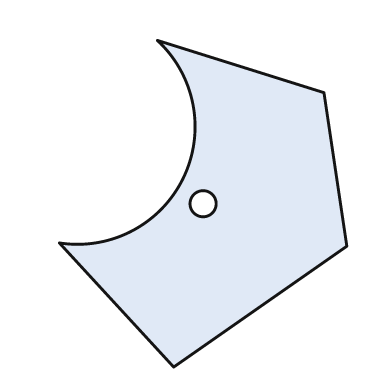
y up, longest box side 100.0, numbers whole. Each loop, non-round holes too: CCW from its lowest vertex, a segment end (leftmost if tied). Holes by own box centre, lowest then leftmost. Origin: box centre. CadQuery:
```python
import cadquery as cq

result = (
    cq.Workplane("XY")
    .moveTo(-9.0, -50.0)
    .lineTo(44.0, -13.0)
    .lineTo(37.0, 34.0)
    .lineTo(-14.0, 50.0)
    .threePointArc((-6.0, 8.0), (-44.0, -12.0))
    .close()
    .moveTo(0.0, 0.0)
    .circle(4.0)
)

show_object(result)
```